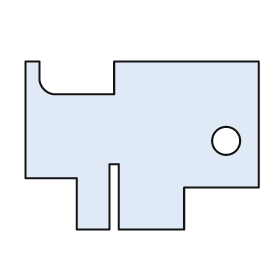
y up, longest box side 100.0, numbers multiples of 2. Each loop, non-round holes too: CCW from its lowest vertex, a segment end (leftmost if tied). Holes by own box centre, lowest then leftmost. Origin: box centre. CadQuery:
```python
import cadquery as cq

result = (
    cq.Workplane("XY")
    .moveTo(-28.0, -36.0)
    .lineTo(-14.0, -36.0)
    .lineTo(-14.0, -8.0)
    .lineTo(-10.0, -8.0)
    .lineTo(-10.0, -36.0)
    .lineTo(18.0, -36.0)
    .lineTo(18.0, -18.0)
    .lineTo(50.0, -18.0)
    .lineTo(50.0, 36.0)
    .lineTo(-12.0, 36.0)
    .lineTo(-12.0, 22.0)
    .lineTo(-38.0, 22.0)
    .threePointArc((-42.0, 24.0), (-44.0, 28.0))
    .lineTo(-44.0, 36.0)
    .lineTo(-50.0, 36.0)
    .lineTo(-50.0, -14.0)
    .lineTo(-28.0, -14.0)
    .close()
    .moveTo(36.0, 2.0)
    .circle(6.0)
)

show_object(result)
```